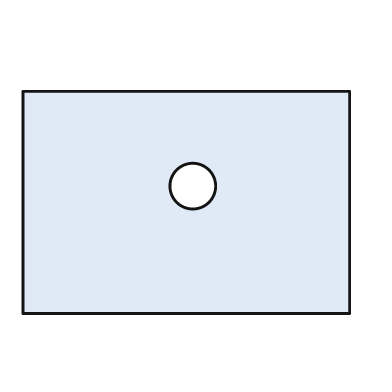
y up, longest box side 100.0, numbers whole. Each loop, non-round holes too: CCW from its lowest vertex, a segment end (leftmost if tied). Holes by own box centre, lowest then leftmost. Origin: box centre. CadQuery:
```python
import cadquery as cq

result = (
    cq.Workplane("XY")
    .moveTo(-50.0, -34.0)
    .lineTo(50.0, -34.0)
    .lineTo(50.0, 34.0)
    .lineTo(-50.0, 34.0)
    .close()
    .moveTo(2.0, 5.0)
    .circle(7.0)
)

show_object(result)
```